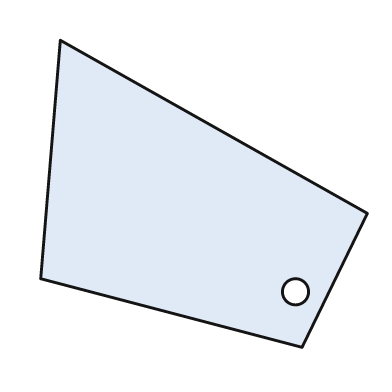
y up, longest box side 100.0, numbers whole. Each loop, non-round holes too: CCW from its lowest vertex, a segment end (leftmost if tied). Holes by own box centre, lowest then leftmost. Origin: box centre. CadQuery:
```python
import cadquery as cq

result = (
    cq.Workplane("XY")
    .moveTo(30.0, -47.0)
    .lineTo(50.0, -6.0)
    .lineTo(-44.0, 47.0)
    .lineTo(-50.0, -26.0)
    .close()
    .moveTo(28.0, -30.0)
    .circle(4.0)
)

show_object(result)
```